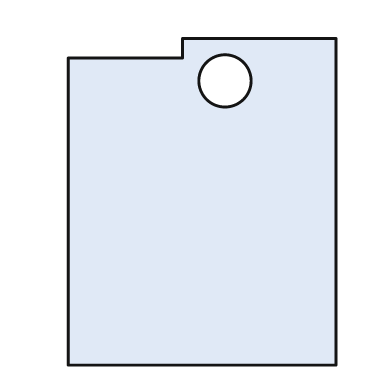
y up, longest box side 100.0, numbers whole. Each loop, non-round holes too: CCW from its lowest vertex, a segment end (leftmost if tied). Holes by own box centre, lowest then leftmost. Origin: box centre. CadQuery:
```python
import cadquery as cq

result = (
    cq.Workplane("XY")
    .moveTo(-41.0, -50.0)
    .lineTo(41.0, -50.0)
    .lineTo(41.0, 50.0)
    .lineTo(-6.0, 50.0)
    .lineTo(-6.0, 44.0)
    .lineTo(-41.0, 44.0)
    .close()
    .moveTo(7.0, 37.0)
    .circle(8.0)
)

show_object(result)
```